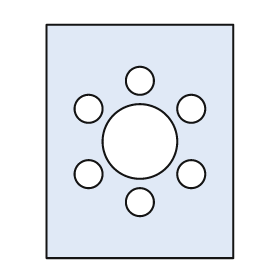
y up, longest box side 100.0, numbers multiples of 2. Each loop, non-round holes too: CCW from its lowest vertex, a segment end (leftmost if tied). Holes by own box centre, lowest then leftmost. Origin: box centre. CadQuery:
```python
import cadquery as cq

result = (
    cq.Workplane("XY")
    .moveTo(-40.0, -50.0)
    .lineTo(40.0, -50.0)
    .lineTo(40.0, 50.0)
    .lineTo(-40.0, 50.0)
    .close()
    .moveTo(0.0, -26.0)
    .circle(6.0)
    .moveTo(-22.0, -14.0)
    .circle(6.0)
    .moveTo(22.0, -14.0)
    .circle(6.0)
    .moveTo(0.0, 0.0)
    .circle(16.0)
    .moveTo(-22.0, 14.0)
    .circle(6.0)
    .moveTo(22.0, 14.0)
    .circle(6.0)
    .moveTo(0.0, 26.0)
    .circle(6.0)
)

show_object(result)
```